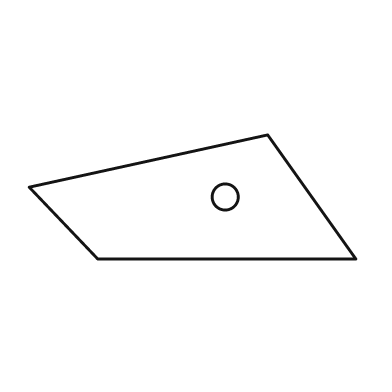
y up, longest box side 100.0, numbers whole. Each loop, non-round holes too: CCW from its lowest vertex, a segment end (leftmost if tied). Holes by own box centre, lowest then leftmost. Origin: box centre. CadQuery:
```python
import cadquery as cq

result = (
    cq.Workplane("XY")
    .moveTo(-29.0, -19.0)
    .lineTo(50.0, -19.0)
    .lineTo(23.0, 19.0)
    .lineTo(-50.0, 3.0)
    .close()
    .moveTo(10.0, 0.0)
    .circle(4.0)
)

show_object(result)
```